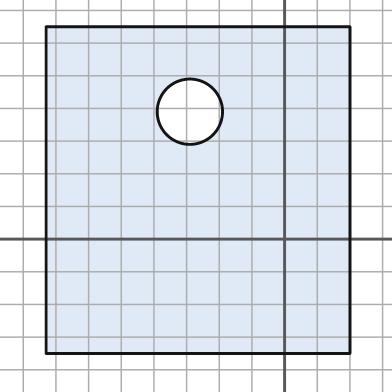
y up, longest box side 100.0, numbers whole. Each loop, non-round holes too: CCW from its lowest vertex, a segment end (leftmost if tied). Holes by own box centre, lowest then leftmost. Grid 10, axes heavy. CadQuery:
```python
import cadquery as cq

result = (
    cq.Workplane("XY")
    .moveTo(-73.0, -35.0)
    .lineTo(20.0, -35.0)
    .lineTo(20.0, 65.0)
    .lineTo(-73.0, 65.0)
    .close()
    .moveTo(-29.0, 39.0)
    .circle(10.0)
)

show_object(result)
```